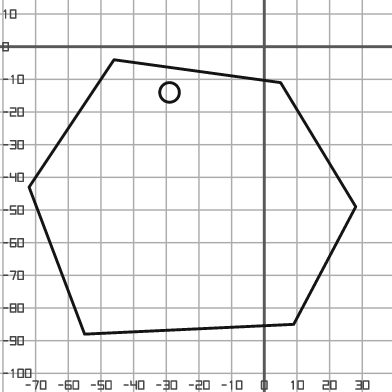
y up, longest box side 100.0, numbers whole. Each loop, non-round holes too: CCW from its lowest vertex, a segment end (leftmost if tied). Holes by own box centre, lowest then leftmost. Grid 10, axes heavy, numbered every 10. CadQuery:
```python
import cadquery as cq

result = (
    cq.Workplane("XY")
    .moveTo(-55.0, -88.0)
    .lineTo(9.0, -85.0)
    .lineTo(28.0, -49.0)
    .lineTo(5.0, -11.0)
    .lineTo(-46.0, -4.0)
    .lineTo(-72.0, -43.0)
    .close()
    .moveTo(-29.0, -14.0)
    .circle(3.0)
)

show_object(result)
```